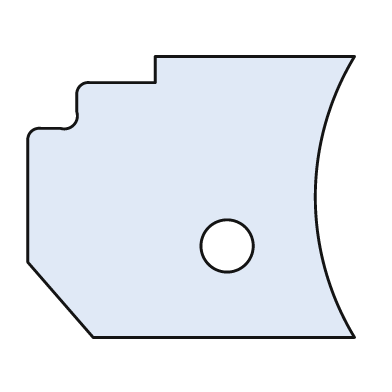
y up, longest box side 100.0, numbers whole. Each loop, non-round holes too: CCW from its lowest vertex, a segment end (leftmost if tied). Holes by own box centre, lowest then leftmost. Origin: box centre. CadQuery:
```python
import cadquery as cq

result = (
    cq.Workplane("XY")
    .moveTo(-30.0, -43.0)
    .lineTo(50.0, -43.0)
    .threePointArc((38.0, 0.0), (50.0, 43.0))
    .lineTo(-11.0, 43.0)
    .lineTo(-11.0, 35.0)
    .lineTo(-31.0, 35.0)
    .threePointArc((-34.0, 34.0), (-35.0, 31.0))
    .lineTo(-35.0, 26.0)
    .threePointArc((-36.0, 22.0), (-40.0, 21.0))
    .lineTo(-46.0, 21.0)
    .threePointArc((-49.0, 20.0), (-50.0, 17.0))
    .lineTo(-50.0, -20.0)
    .close()
    .moveTo(11.0, -15.0)
    .circle(8.0)
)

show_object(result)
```